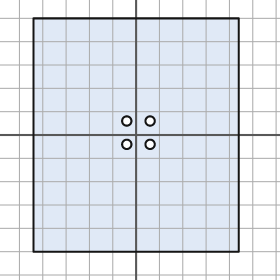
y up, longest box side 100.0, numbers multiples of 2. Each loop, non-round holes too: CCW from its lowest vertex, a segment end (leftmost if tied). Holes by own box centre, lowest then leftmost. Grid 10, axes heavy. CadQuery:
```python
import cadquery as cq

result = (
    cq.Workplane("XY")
    .moveTo(-44.0, -50.0)
    .lineTo(44.0, -50.0)
    .lineTo(44.0, 50.0)
    .lineTo(-44.0, 50.0)
    .close()
    .moveTo(-4.0, -4.0)
    .circle(2.0)
    .moveTo(6.0, -4.0)
    .circle(2.0)
    .moveTo(-4.0, 6.0)
    .circle(2.0)
    .moveTo(6.0, 6.0)
    .circle(2.0)
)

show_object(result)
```